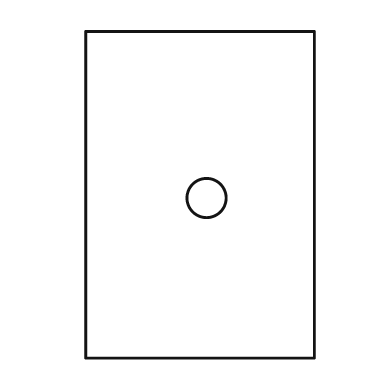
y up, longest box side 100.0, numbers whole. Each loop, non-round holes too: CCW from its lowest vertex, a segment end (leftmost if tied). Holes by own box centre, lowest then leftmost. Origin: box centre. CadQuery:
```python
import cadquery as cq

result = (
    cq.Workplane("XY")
    .moveTo(-35.0, -50.0)
    .lineTo(35.0, -50.0)
    .lineTo(35.0, 50.0)
    .lineTo(-35.0, 50.0)
    .close()
    .moveTo(2.0, -1.0)
    .circle(6.0)
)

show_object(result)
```